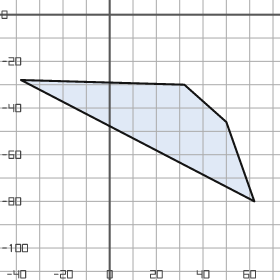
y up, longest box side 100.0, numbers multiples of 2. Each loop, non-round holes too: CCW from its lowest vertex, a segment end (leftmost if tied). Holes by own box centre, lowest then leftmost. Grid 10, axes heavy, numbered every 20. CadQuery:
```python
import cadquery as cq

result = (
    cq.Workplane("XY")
    .moveTo(62.0, -80.0)
    .lineTo(50.0, -46.0)
    .lineTo(32.0, -30.0)
    .lineTo(-38.0, -28.0)
    .close()
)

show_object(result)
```